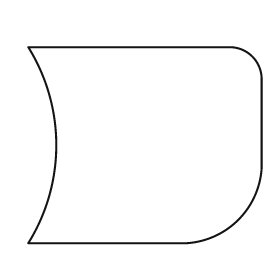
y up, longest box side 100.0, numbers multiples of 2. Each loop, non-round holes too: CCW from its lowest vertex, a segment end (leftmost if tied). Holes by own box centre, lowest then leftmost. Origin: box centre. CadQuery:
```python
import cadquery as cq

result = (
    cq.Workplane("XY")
    .moveTo(-50.0, -42.0)
    .lineTo(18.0, -42.0)
    .threePointArc((40.0, -32.0), (50.0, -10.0))
    .lineTo(50.0, 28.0)
    .threePointArc((46.0, 38.0), (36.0, 42.0))
    .lineTo(-50.0, 42.0)
    .threePointArc((-38.0, 0.0), (-50.0, -42.0))
    .close()
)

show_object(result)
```